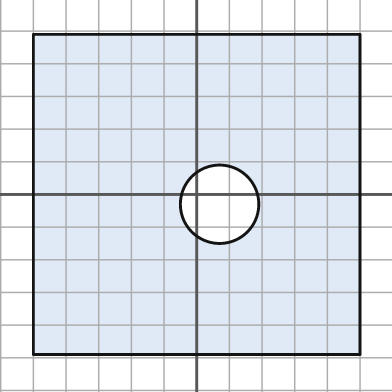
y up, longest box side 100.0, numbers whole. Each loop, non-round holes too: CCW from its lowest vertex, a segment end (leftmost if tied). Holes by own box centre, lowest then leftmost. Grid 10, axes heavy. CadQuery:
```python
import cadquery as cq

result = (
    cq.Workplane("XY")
    .moveTo(-50.0, -49.0)
    .lineTo(50.0, -49.0)
    .lineTo(50.0, 49.0)
    .lineTo(-50.0, 49.0)
    .close()
    .moveTo(7.0, -3.0)
    .circle(12.0)
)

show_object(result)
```